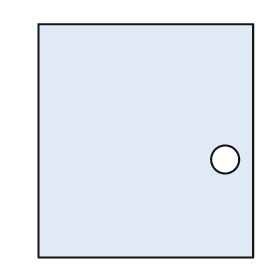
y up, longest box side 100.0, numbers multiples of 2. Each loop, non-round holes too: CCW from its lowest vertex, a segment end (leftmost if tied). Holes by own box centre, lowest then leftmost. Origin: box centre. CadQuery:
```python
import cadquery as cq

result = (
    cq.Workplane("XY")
    .moveTo(-46.0, -50.0)
    .lineTo(46.0, -50.0)
    .lineTo(46.0, 50.0)
    .lineTo(-46.0, 50.0)
    .close()
    .moveTo(34.0, -8.0)
    .circle(6.0)
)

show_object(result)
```